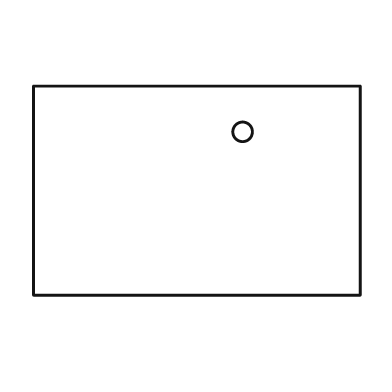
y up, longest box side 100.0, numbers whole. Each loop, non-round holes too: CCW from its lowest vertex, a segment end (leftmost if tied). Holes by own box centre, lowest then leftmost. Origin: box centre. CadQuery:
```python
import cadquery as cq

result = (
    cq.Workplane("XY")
    .moveTo(-50.0, -32.0)
    .lineTo(50.0, -32.0)
    .lineTo(50.0, 32.0)
    .lineTo(-50.0, 32.0)
    .close()
    .moveTo(14.0, 18.0)
    .circle(3.0)
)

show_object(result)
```